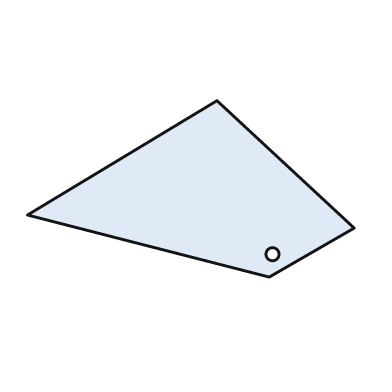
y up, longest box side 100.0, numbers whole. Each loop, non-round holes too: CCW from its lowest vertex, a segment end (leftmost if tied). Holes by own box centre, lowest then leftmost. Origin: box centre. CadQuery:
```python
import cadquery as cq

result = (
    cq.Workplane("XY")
    .moveTo(24.0, -27.0)
    .lineTo(50.0, -12.0)
    .lineTo(8.0, 27.0)
    .lineTo(-50.0, -8.0)
    .close()
    .moveTo(25.0, -20.0)
    .circle(2.0)
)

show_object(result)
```